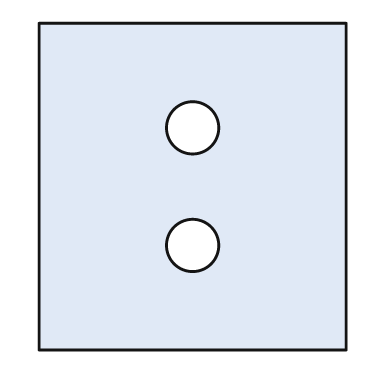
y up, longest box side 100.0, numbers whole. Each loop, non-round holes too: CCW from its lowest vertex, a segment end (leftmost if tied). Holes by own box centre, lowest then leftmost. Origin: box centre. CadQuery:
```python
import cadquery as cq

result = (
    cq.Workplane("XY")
    .moveTo(-47.0, -50.0)
    .lineTo(47.0, -50.0)
    .lineTo(47.0, 50.0)
    .lineTo(-47.0, 50.0)
    .close()
    .moveTo(0.0, -18.0)
    .circle(8.0)
    .moveTo(0.0, 18.0)
    .circle(8.0)
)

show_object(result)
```